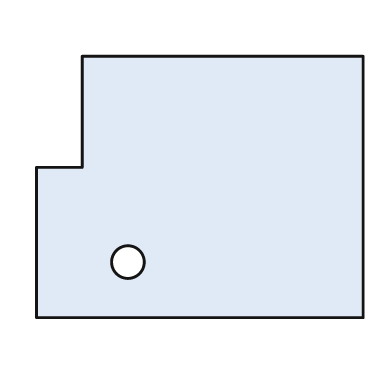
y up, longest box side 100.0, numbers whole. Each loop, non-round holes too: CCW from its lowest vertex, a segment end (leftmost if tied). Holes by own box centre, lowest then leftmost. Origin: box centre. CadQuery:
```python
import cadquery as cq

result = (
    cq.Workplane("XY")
    .moveTo(-50.0, -40.0)
    .lineTo(50.0, -40.0)
    .lineTo(50.0, 40.0)
    .lineTo(-36.0, 40.0)
    .lineTo(-36.0, 6.0)
    .lineTo(-50.0, 6.0)
    .close()
    .moveTo(-22.0, -23.0)
    .circle(5.0)
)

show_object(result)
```